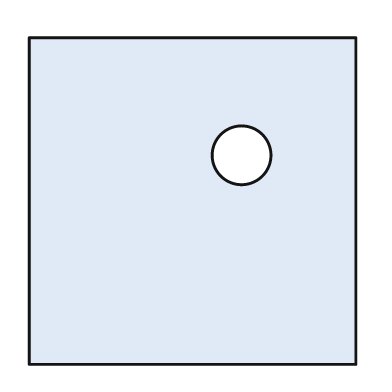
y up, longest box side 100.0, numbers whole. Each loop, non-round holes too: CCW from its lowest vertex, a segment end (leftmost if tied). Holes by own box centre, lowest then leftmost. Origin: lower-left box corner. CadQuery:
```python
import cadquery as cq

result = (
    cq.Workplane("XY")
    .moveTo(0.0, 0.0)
    .lineTo(100.0, 0.0)
    .lineTo(100.0, 100.0)
    .lineTo(0.0, 100.0)
    .close()
    .moveTo(65.0, 64.0)
    .circle(9.0)
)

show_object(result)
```